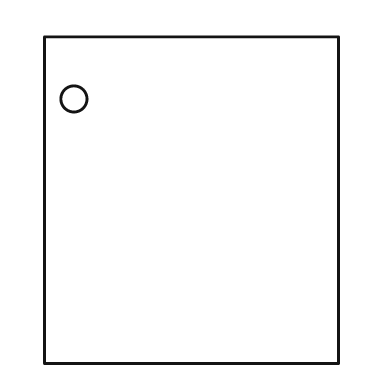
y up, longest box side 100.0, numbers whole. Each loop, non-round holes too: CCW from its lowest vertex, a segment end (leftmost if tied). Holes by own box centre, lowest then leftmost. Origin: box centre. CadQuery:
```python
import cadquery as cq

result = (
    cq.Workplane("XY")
    .moveTo(-45.0, -50.0)
    .lineTo(45.0, -50.0)
    .lineTo(45.0, 50.0)
    .lineTo(-45.0, 50.0)
    .close()
    .moveTo(-36.0, 31.0)
    .circle(4.0)
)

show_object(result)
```